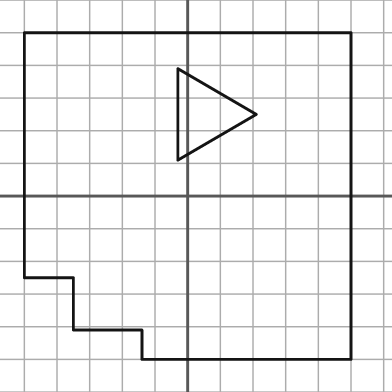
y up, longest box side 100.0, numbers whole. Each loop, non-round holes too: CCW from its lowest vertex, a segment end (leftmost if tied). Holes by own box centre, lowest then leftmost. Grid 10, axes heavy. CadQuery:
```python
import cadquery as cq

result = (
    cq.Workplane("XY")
    .moveTo(-14.0, -50.0)
    .lineTo(50.0, -50.0)
    .lineTo(50.0, 50.0)
    .lineTo(-50.0, 50.0)
    .lineTo(-50.0, -25.0)
    .lineTo(-35.0, -25.0)
    .lineTo(-35.0, -41.0)
    .lineTo(-14.0, -41.0)
    .close()
    .moveTo(-3.0, 11.0)
    .lineTo(21.0, 25.0)
    .lineTo(-3.0, 39.0)
    .close()
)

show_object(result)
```